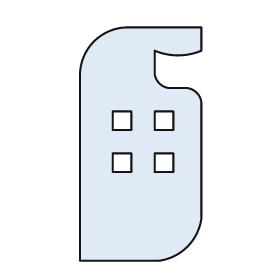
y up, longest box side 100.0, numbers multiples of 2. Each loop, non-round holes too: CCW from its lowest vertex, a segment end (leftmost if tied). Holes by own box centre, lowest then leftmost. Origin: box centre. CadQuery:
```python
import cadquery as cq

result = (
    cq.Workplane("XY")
    .moveTo(-26.0, -50.0)
    .lineTo(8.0, -50.0)
    .threePointArc((20.0, -44.0), (26.0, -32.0))
    .lineTo(26.0, 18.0)
    .threePointArc((24.0, 22.0), (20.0, 24.0))
    .lineTo(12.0, 24.0)
    .threePointArc((8.0, 26.0), (6.0, 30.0))
    .lineTo(6.0, 40.0)
    .threePointArc((16.0, 38.0), (26.0, 40.0))
    .lineTo(26.0, 50.0)
    .lineTo(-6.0, 50.0)
    .threePointArc((-20.0, 44.0), (-26.0, 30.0))
    .close()
    .moveTo(-12.0, -12.0)
    .lineTo(-4.0, -12.0)
    .lineTo(-4.0, -4.0)
    .lineTo(-12.0, -4.0)
    .close()
    .moveTo(6.0, -12.0)
    .lineTo(14.0, -12.0)
    .lineTo(14.0, -4.0)
    .lineTo(6.0, -4.0)
    .close()
    .moveTo(-12.0, 6.0)
    .lineTo(-4.0, 6.0)
    .lineTo(-4.0, 14.0)
    .lineTo(-12.0, 14.0)
    .close()
    .moveTo(6.0, 6.0)
    .lineTo(14.0, 6.0)
    .lineTo(14.0, 14.0)
    .lineTo(6.0, 14.0)
    .close()
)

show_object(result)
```